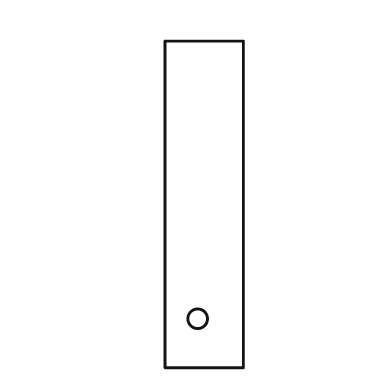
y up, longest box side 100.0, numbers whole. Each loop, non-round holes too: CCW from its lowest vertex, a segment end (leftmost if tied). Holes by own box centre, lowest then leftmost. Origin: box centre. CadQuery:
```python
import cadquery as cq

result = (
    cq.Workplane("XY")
    .moveTo(-12.0, -50.0)
    .lineTo(12.0, -50.0)
    .lineTo(12.0, 50.0)
    .lineTo(-12.0, 50.0)
    .close()
    .moveTo(-2.0, -35.0)
    .circle(3.0)
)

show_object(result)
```